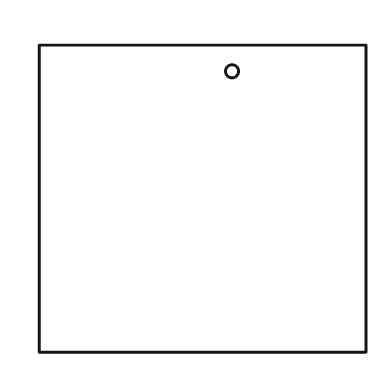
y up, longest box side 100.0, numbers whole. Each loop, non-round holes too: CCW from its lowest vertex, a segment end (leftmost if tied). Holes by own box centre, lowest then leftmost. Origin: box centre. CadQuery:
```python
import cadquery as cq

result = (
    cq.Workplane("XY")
    .moveTo(-50.0, -47.0)
    .lineTo(50.0, -47.0)
    .lineTo(50.0, 47.0)
    .lineTo(-50.0, 47.0)
    .close()
    .moveTo(9.0, 39.0)
    .circle(2.0)
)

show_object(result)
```